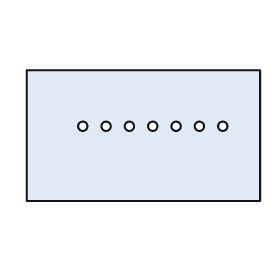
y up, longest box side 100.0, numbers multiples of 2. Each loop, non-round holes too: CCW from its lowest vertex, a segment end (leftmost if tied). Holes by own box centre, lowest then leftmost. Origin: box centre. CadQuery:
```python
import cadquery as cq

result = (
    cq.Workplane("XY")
    .moveTo(-50.0, -28.0)
    .lineTo(50.0, -28.0)
    .lineTo(50.0, 28.0)
    .lineTo(-50.0, 28.0)
    .close()
    .moveTo(-26.0, 4.0)
    .circle(2.0)
    .moveTo(-16.0, 4.0)
    .circle(2.0)
    .moveTo(-6.0, 4.0)
    .circle(2.0)
    .moveTo(4.0, 4.0)
    .circle(2.0)
    .moveTo(14.0, 4.0)
    .circle(2.0)
    .moveTo(24.0, 4.0)
    .circle(2.0)
    .moveTo(34.0, 4.0)
    .circle(2.0)
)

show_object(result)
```